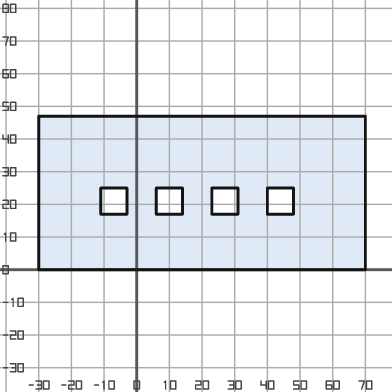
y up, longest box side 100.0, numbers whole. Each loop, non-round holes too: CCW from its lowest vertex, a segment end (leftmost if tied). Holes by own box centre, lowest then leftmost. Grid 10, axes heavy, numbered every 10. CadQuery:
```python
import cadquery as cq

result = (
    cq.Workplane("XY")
    .moveTo(-30.0, 0.0)
    .lineTo(70.0, 0.0)
    .lineTo(70.0, 47.0)
    .lineTo(-30.0, 47.0)
    .close()
    .moveTo(-11.0, 17.0)
    .lineTo(-3.0, 17.0)
    .lineTo(-3.0, 25.0)
    .lineTo(-11.0, 25.0)
    .close()
    .moveTo(6.0, 17.0)
    .lineTo(14.0, 17.0)
    .lineTo(14.0, 25.0)
    .lineTo(6.0, 25.0)
    .close()
    .moveTo(23.0, 17.0)
    .lineTo(31.0, 17.0)
    .lineTo(31.0, 25.0)
    .lineTo(23.0, 25.0)
    .close()
    .moveTo(40.0, 17.0)
    .lineTo(48.0, 17.0)
    .lineTo(48.0, 25.0)
    .lineTo(40.0, 25.0)
    .close()
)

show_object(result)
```